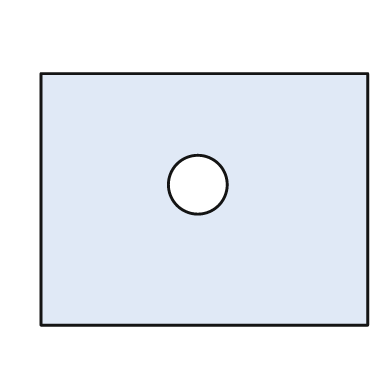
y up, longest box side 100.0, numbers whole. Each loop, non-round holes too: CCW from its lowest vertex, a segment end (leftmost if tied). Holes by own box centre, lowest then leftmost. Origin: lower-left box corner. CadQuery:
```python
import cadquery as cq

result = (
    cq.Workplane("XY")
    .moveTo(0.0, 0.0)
    .lineTo(100.0, 0.0)
    .lineTo(100.0, 77.0)
    .lineTo(0.0, 77.0)
    .close()
    .moveTo(48.0, 43.0)
    .circle(9.0)
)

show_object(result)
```